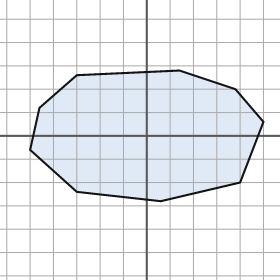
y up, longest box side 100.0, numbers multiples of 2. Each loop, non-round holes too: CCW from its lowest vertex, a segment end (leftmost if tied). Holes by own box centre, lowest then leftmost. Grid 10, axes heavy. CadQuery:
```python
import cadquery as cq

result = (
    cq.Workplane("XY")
    .moveTo(6.0, -28.0)
    .lineTo(40.0, -20.0)
    .lineTo(50.0, 6.0)
    .lineTo(38.0, 20.0)
    .lineTo(14.0, 28.0)
    .lineTo(-30.0, 26.0)
    .lineTo(-46.0, 12.0)
    .lineTo(-50.0, -6.0)
    .lineTo(-30.0, -24.0)
    .close()
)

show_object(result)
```